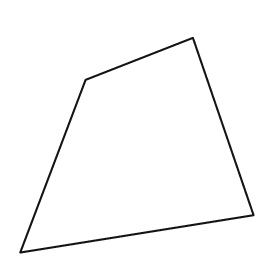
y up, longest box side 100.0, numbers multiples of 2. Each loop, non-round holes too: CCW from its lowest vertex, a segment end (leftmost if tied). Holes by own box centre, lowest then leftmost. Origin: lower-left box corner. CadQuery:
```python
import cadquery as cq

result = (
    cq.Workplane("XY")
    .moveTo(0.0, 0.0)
    .lineTo(100.0, 16.0)
    .lineTo(74.0, 92.0)
    .lineTo(28.0, 74.0)
    .close()
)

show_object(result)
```